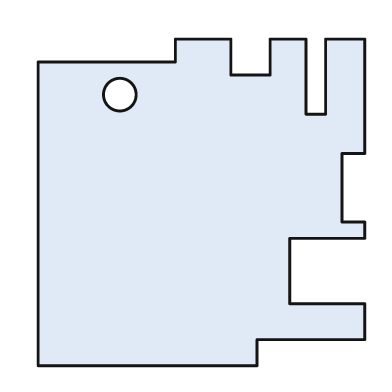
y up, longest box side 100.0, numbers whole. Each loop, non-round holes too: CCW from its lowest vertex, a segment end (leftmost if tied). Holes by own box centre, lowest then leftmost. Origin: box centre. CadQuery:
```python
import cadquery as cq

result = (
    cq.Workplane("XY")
    .moveTo(-50.0, -50.0)
    .lineTo(17.0, -50.0)
    .lineTo(17.0, -42.0)
    .lineTo(50.0, -42.0)
    .lineTo(50.0, -31.0)
    .lineTo(27.0, -31.0)
    .lineTo(27.0, -11.0)
    .lineTo(50.0, -11.0)
    .lineTo(50.0, -6.0)
    .lineTo(43.0, -6.0)
    .lineTo(43.0, 15.0)
    .lineTo(50.0, 15.0)
    .lineTo(50.0, 50.0)
    .lineTo(38.0, 50.0)
    .lineTo(38.0, 27.0)
    .lineTo(32.0, 27.0)
    .lineTo(32.0, 50.0)
    .lineTo(21.0, 50.0)
    .lineTo(21.0, 39.0)
    .lineTo(9.0, 39.0)
    .lineTo(9.0, 50.0)
    .lineTo(-8.0, 50.0)
    .lineTo(-8.0, 43.0)
    .lineTo(-50.0, 43.0)
    .close()
    .moveTo(-25.0, 33.0)
    .circle(5.0)
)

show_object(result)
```